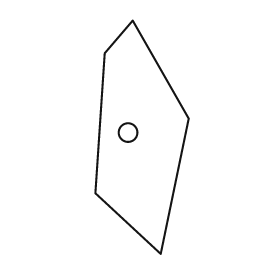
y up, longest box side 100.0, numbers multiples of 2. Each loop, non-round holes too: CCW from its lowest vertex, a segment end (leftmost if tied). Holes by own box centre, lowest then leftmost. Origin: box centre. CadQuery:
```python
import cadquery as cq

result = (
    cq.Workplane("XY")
    .moveTo(8.0, -50.0)
    .lineTo(20.0, 8.0)
    .lineTo(-4.0, 50.0)
    .lineTo(-16.0, 36.0)
    .lineTo(-20.0, -24.0)
    .close()
    .moveTo(-6.0, 2.0)
    .circle(4.0)
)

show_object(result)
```